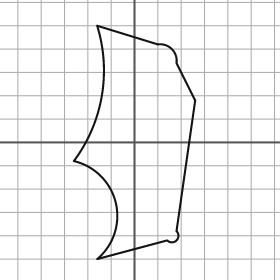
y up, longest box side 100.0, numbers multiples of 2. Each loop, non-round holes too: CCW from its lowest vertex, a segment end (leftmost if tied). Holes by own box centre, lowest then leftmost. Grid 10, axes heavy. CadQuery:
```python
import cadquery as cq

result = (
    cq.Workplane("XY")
    .moveTo(-16.0, -50.0)
    .lineTo(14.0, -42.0)
    .threePointArc((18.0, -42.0), (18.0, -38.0))
    .lineTo(26.0, 18.0)
    .lineTo(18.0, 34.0)
    .threePointArc((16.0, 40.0), (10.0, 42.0))
    .lineTo(-16.0, 50.0)
    .threePointArc((-14.0, 20.0), (-26.0, -8.0))
    .threePointArc((-8.0, -26.0), (-16.0, -50.0))
    .close()
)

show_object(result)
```